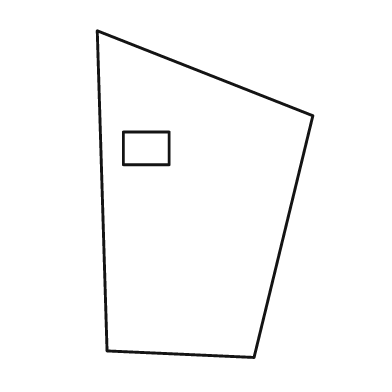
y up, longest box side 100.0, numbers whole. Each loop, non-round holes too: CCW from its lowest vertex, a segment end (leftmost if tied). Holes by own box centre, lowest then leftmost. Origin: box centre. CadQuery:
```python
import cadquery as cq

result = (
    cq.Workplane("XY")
    .moveTo(15.0, -50.0)
    .lineTo(33.0, 24.0)
    .lineTo(-33.0, 50.0)
    .lineTo(-30.0, -48.0)
    .close()
    .moveTo(-25.0, 9.0)
    .lineTo(-11.0, 9.0)
    .lineTo(-11.0, 19.0)
    .lineTo(-25.0, 19.0)
    .close()
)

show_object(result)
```